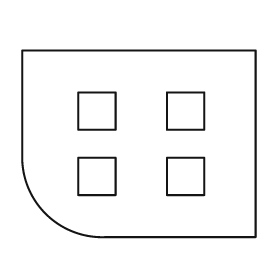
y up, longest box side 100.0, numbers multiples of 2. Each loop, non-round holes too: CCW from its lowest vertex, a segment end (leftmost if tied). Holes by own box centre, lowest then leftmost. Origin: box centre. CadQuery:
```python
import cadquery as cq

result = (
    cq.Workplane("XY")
    .moveTo(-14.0, -40.0)
    .lineTo(50.0, -40.0)
    .lineTo(50.0, 40.0)
    .lineTo(-50.0, 40.0)
    .lineTo(-50.0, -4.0)
    .threePointArc((-40.0, -30.0), (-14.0, -40.0))
    .close()
    .moveTo(-26.0, -22.0)
    .lineTo(-10.0, -22.0)
    .lineTo(-10.0, -6.0)
    .lineTo(-26.0, -6.0)
    .close()
    .moveTo(12.0, -22.0)
    .lineTo(28.0, -22.0)
    .lineTo(28.0, -6.0)
    .lineTo(12.0, -6.0)
    .close()
    .moveTo(-26.0, 6.0)
    .lineTo(-10.0, 6.0)
    .lineTo(-10.0, 22.0)
    .lineTo(-26.0, 22.0)
    .close()
    .moveTo(12.0, 6.0)
    .lineTo(28.0, 6.0)
    .lineTo(28.0, 22.0)
    .lineTo(12.0, 22.0)
    .close()
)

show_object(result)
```